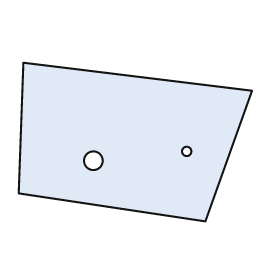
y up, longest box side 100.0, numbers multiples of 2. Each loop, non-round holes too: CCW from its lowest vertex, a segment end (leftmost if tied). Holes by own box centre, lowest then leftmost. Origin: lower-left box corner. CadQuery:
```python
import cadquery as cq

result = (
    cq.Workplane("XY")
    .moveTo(80.0, 0.0)
    .lineTo(100.0, 56.0)
    .lineTo(2.0, 68.0)
    .lineTo(0.0, 12.0)
    .close()
    .moveTo(32.0, 26.0)
    .circle(4.0)
    .moveTo(72.0, 30.0)
    .circle(2.0)
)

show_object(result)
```